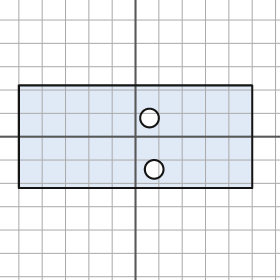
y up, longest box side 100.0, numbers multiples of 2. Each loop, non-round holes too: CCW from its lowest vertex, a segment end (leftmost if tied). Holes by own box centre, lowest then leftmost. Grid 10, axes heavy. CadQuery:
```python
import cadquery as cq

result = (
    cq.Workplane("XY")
    .moveTo(-50.0, -22.0)
    .lineTo(50.0, -22.0)
    .lineTo(50.0, 22.0)
    .lineTo(-50.0, 22.0)
    .close()
    .moveTo(8.0, -14.0)
    .circle(4.0)
    .moveTo(6.0, 8.0)
    .circle(4.0)
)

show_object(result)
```